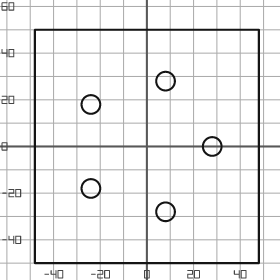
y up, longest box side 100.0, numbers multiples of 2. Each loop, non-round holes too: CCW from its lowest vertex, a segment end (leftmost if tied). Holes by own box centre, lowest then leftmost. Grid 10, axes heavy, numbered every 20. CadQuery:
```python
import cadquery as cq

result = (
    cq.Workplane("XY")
    .moveTo(-48.0, -50.0)
    .lineTo(48.0, -50.0)
    .lineTo(48.0, 50.0)
    .lineTo(-48.0, 50.0)
    .close()
    .moveTo(8.0, -28.0)
    .circle(4.0)
    .moveTo(-24.0, -18.0)
    .circle(4.0)
    .moveTo(28.0, 0.0)
    .circle(4.0)
    .moveTo(-24.0, 18.0)
    .circle(4.0)
    .moveTo(8.0, 28.0)
    .circle(4.0)
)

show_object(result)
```